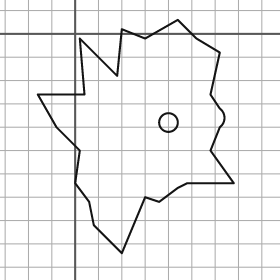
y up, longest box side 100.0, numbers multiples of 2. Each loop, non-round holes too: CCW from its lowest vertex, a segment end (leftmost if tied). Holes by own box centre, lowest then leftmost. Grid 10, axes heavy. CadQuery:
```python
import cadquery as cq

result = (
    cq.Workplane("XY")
    .moveTo(20.0, -94.0)
    .lineTo(30.0, -70.0)
    .lineTo(36.0, -72.0)
    .lineTo(44.0, -66.0)
    .lineTo(48.0, -64.0)
    .lineTo(68.0, -64.0)
    .lineTo(58.0, -50.0)
    .lineTo(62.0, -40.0)
    .threePointArc((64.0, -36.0), (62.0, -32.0))
    .lineTo(58.0, -26.0)
    .lineTo(62.0, -8.0)
    .lineTo(52.0, -2.0)
    .lineTo(44.0, 6.0)
    .lineTo(30.0, -2.0)
    .lineTo(20.0, 2.0)
    .lineTo(18.0, -18.0)
    .lineTo(2.0, -2.0)
    .lineTo(4.0, -26.0)
    .lineTo(-16.0, -26.0)
    .lineTo(-8.0, -40.0)
    .lineTo(2.0, -50.0)
    .lineTo(0.0, -64.0)
    .lineTo(6.0, -72.0)
    .lineTo(8.0, -82.0)
    .close()
    .moveTo(40.0, -38.0)
    .circle(4.0)
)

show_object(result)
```